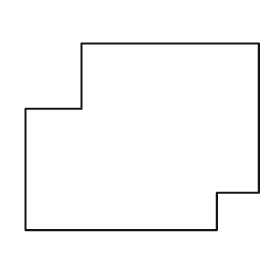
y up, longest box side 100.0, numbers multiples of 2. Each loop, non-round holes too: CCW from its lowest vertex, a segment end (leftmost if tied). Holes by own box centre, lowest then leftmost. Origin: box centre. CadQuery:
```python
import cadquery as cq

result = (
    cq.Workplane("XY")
    .moveTo(-50.0, -40.0)
    .lineTo(32.0, -40.0)
    .lineTo(32.0, -24.0)
    .lineTo(50.0, -24.0)
    .lineTo(50.0, 40.0)
    .lineTo(-26.0, 40.0)
    .lineTo(-26.0, 12.0)
    .lineTo(-50.0, 12.0)
    .close()
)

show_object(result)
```